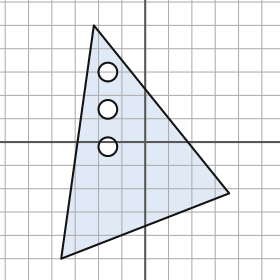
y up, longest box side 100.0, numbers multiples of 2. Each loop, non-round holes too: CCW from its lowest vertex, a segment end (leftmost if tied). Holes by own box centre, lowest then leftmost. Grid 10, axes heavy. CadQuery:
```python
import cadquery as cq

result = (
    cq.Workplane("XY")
    .moveTo(-36.0, -50.0)
    .lineTo(36.0, -22.0)
    .lineTo(-22.0, 50.0)
    .close()
    .moveTo(-16.0, -2.0)
    .circle(4.0)
    .moveTo(-16.0, 14.0)
    .circle(4.0)
    .moveTo(-16.0, 30.0)
    .circle(4.0)
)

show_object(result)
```